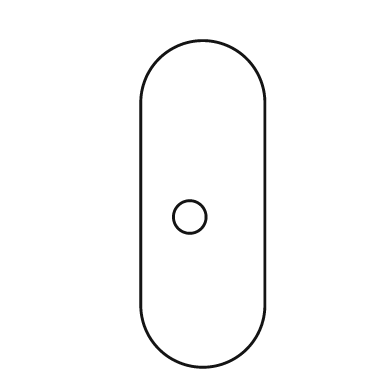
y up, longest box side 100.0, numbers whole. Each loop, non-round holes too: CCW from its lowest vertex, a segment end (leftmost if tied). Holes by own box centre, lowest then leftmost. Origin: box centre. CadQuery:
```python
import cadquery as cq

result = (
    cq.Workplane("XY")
    .moveTo(-19.0, -31.0)
    .threePointArc((0.0, -50.0), (19.0, -31.0))
    .lineTo(19.0, 31.0)
    .threePointArc((0.0, 50.0), (-19.0, 31.0))
    .close()
    .moveTo(-4.0, -4.0)
    .circle(5.0)
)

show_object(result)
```